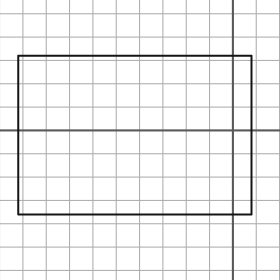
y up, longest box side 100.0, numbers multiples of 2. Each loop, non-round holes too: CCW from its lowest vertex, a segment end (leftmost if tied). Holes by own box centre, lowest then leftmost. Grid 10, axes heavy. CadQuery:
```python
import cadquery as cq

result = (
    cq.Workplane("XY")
    .moveTo(-92.0, -36.0)
    .lineTo(8.0, -36.0)
    .lineTo(8.0, 32.0)
    .lineTo(-92.0, 32.0)
    .close()
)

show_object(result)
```